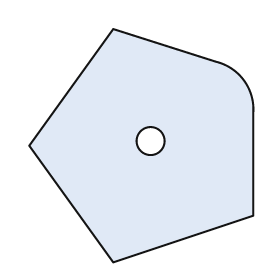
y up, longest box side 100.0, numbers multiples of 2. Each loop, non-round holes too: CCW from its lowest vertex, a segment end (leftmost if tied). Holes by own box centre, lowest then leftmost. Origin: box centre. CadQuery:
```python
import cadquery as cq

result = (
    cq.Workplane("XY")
    .moveTo(-12.0, -50.0)
    .lineTo(48.0, -30.0)
    .lineTo(48.0, 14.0)
    .threePointArc((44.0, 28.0), (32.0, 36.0))
    .lineTo(-12.0, 50.0)
    .lineTo(-48.0, 0.0)
    .close()
    .moveTo(4.0, 2.0)
    .circle(6.0)
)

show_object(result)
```